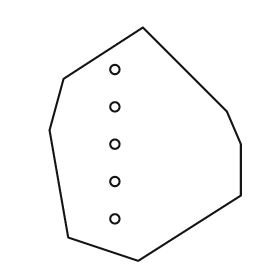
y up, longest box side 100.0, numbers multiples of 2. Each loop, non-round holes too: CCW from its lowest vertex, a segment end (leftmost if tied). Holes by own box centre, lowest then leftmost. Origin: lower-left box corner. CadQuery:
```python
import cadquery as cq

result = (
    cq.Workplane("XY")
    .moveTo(38.0, 0.0)
    .lineTo(82.0, 28.0)
    .lineTo(82.0, 50.0)
    .lineTo(76.0, 64.0)
    .lineTo(40.0, 100.0)
    .lineTo(6.0, 78.0)
    .lineTo(0.0, 56.0)
    .lineTo(8.0, 10.0)
    .close()
    .moveTo(28.0, 18.0)
    .circle(2.0)
    .moveTo(28.0, 34.0)
    .circle(2.0)
    .moveTo(28.0, 50.0)
    .circle(2.0)
    .moveTo(28.0, 66.0)
    .circle(2.0)
    .moveTo(28.0, 82.0)
    .circle(2.0)
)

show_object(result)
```